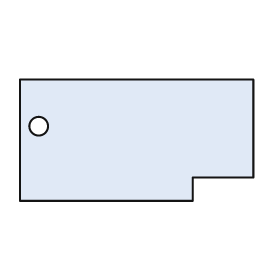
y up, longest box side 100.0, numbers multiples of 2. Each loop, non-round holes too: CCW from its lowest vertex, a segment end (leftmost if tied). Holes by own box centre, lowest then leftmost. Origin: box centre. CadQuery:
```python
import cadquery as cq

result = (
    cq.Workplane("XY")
    .moveTo(-50.0, -26.0)
    .lineTo(24.0, -26.0)
    .lineTo(24.0, -16.0)
    .lineTo(50.0, -16.0)
    .lineTo(50.0, 26.0)
    .lineTo(-50.0, 26.0)
    .close()
    .moveTo(-42.0, 6.0)
    .circle(4.0)
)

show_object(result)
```